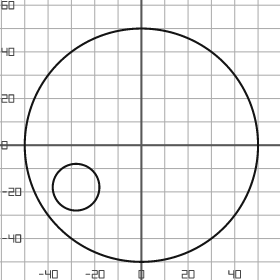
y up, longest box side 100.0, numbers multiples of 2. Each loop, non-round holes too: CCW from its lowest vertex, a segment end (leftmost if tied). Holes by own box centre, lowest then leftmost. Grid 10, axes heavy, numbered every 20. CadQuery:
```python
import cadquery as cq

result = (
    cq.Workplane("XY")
    .moveTo(0.0, 0.0)
    .circle(50.0)
    .moveTo(-28.0, -18.0)
    .circle(10.0)
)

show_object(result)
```